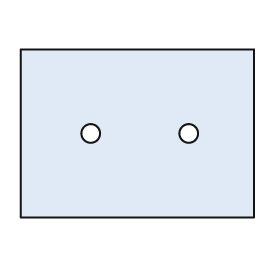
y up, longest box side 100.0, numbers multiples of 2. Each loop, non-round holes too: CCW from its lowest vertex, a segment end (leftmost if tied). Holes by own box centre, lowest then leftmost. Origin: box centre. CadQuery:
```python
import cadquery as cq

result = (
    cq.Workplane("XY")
    .moveTo(-50.0, -36.0)
    .lineTo(50.0, -36.0)
    .lineTo(50.0, 36.0)
    .lineTo(-50.0, 36.0)
    .close()
    .moveTo(-20.0, 0.0)
    .circle(4.0)
    .moveTo(22.0, 0.0)
    .circle(4.0)
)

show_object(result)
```